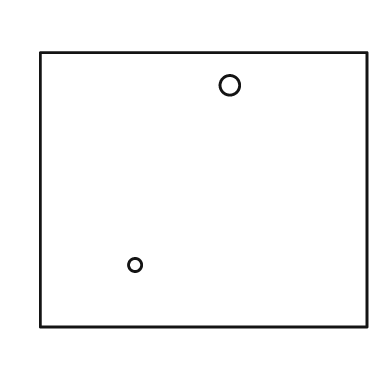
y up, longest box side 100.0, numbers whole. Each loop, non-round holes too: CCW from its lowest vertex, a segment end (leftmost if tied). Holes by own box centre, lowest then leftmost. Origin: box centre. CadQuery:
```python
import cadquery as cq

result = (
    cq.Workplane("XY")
    .moveTo(-50.0, -42.0)
    .lineTo(50.0, -42.0)
    .lineTo(50.0, 42.0)
    .lineTo(-50.0, 42.0)
    .close()
    .moveTo(-21.0, -23.0)
    .circle(2.0)
    .moveTo(8.0, 32.0)
    .circle(3.0)
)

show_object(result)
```